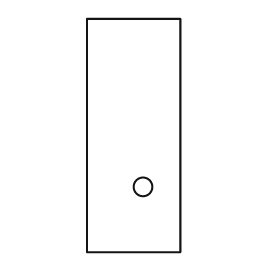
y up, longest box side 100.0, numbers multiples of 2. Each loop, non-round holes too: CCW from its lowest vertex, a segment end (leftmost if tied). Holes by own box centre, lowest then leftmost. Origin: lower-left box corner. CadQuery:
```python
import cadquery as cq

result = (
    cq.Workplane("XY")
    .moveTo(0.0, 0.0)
    .lineTo(40.0, 0.0)
    .lineTo(40.0, 100.0)
    .lineTo(0.0, 100.0)
    .close()
    .moveTo(24.0, 28.0)
    .circle(4.0)
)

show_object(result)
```